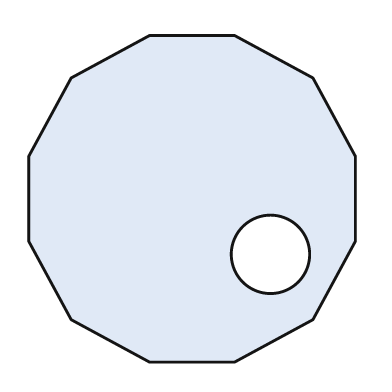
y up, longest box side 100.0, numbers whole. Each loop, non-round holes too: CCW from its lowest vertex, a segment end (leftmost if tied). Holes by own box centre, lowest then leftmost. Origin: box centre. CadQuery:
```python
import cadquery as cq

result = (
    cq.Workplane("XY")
    .moveTo(-13.0, -50.0)
    .lineTo(13.0, -50.0)
    .lineTo(37.0, -37.0)
    .lineTo(50.0, -13.0)
    .lineTo(50.0, 13.0)
    .lineTo(37.0, 37.0)
    .lineTo(13.0, 50.0)
    .lineTo(-13.0, 50.0)
    .lineTo(-37.0, 37.0)
    .lineTo(-50.0, 13.0)
    .lineTo(-50.0, -13.0)
    .lineTo(-37.0, -37.0)
    .close()
    .moveTo(24.0, -17.0)
    .circle(12.0)
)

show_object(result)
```